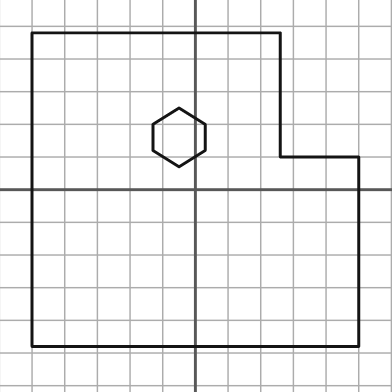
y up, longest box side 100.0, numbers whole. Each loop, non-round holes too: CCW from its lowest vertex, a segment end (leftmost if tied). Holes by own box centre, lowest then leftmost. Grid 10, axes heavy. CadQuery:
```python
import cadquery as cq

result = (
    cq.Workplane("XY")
    .moveTo(-50.0, -48.0)
    .lineTo(50.0, -48.0)
    .lineTo(50.0, 10.0)
    .lineTo(26.0, 10.0)
    .lineTo(26.0, 48.0)
    .lineTo(-50.0, 48.0)
    .close()
    .moveTo(-5.0, 7.0)
    .lineTo(3.0, 12.0)
    .lineTo(3.0, 20.0)
    .lineTo(-5.0, 25.0)
    .lineTo(-13.0, 20.0)
    .lineTo(-13.0, 12.0)
    .close()
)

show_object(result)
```